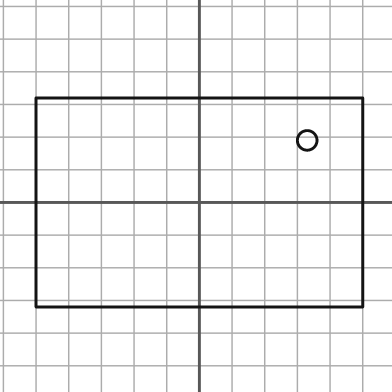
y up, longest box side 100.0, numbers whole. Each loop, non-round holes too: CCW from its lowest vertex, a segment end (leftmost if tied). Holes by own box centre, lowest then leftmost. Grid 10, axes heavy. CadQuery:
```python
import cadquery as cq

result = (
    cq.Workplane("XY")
    .moveTo(-50.0, -32.0)
    .lineTo(50.0, -32.0)
    .lineTo(50.0, 32.0)
    .lineTo(-50.0, 32.0)
    .close()
    .moveTo(33.0, 19.0)
    .circle(3.0)
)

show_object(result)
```